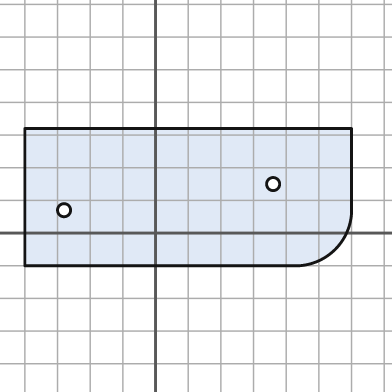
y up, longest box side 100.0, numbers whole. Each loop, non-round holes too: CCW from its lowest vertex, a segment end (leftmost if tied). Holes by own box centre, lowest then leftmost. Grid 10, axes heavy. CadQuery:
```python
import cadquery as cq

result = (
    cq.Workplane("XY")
    .moveTo(-40.0, -10.0)
    .lineTo(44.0, -10.0)
    .threePointArc((55.0, -5.0), (60.0, 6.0))
    .lineTo(60.0, 32.0)
    .lineTo(-40.0, 32.0)
    .close()
    .moveTo(-28.0, 7.0)
    .circle(2.0)
    .moveTo(36.0, 15.0)
    .circle(2.0)
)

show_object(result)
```